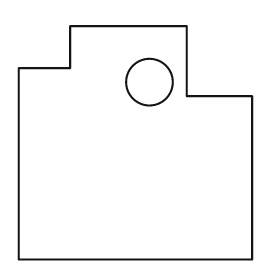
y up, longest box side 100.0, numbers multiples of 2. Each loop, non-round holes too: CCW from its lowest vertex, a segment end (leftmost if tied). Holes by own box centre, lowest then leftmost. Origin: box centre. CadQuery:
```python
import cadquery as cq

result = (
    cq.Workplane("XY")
    .moveTo(-50.0, -50.0)
    .lineTo(50.0, -50.0)
    .lineTo(50.0, 20.0)
    .lineTo(22.0, 20.0)
    .lineTo(22.0, 50.0)
    .lineTo(-28.0, 50.0)
    .lineTo(-28.0, 32.0)
    .lineTo(-50.0, 32.0)
    .close()
    .moveTo(6.0, 26.0)
    .circle(10.0)
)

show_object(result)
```